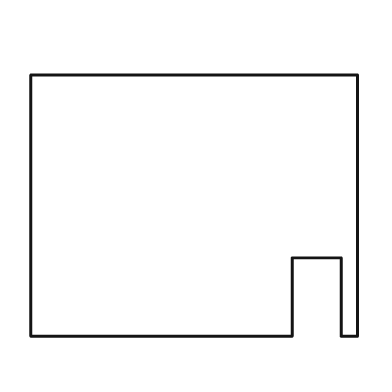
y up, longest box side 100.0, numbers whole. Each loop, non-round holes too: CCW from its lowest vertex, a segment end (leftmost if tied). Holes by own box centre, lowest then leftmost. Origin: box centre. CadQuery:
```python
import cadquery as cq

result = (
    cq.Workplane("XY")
    .moveTo(-50.0, -40.0)
    .lineTo(30.0, -40.0)
    .lineTo(30.0, -16.0)
    .lineTo(45.0, -16.0)
    .lineTo(45.0, -40.0)
    .lineTo(50.0, -40.0)
    .lineTo(50.0, 40.0)
    .lineTo(-50.0, 40.0)
    .close()
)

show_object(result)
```